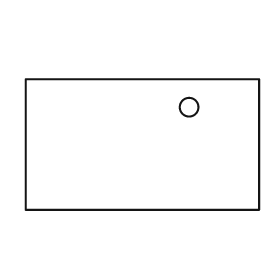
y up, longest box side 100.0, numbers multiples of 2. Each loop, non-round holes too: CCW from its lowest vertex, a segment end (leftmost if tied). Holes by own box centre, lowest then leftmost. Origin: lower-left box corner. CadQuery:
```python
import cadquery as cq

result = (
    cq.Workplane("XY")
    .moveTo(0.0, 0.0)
    .lineTo(100.0, 0.0)
    .lineTo(100.0, 56.0)
    .lineTo(0.0, 56.0)
    .close()
    .moveTo(70.0, 44.0)
    .circle(4.0)
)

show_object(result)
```